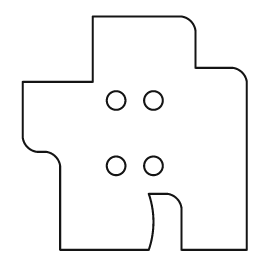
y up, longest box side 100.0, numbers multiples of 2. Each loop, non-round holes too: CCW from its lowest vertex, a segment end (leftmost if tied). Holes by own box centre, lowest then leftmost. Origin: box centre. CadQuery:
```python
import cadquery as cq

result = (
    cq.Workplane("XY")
    .moveTo(-32.0, -50.0)
    .lineTo(6.0, -50.0)
    .threePointArc((8.0, -38.0), (6.0, -26.0))
    .lineTo(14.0, -26.0)
    .threePointArc((18.0, -28.0), (20.0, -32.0))
    .lineTo(20.0, -50.0)
    .lineTo(48.0, -50.0)
    .lineTo(48.0, 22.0)
    .threePointArc((46.0, 26.0), (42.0, 28.0))
    .lineTo(26.0, 28.0)
    .lineTo(26.0, 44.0)
    .threePointArc((24.0, 48.0), (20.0, 50.0))
    .lineTo(-18.0, 50.0)
    .lineTo(-18.0, 22.0)
    .lineTo(-48.0, 22.0)
    .lineTo(-48.0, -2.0)
    .threePointArc((-46.0, -6.0), (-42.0, -8.0))
    .lineTo(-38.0, -8.0)
    .threePointArc((-34.0, -10.0), (-32.0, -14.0))
    .close()
    .moveTo(-8.0, -14.0)
    .circle(4.0)
    .moveTo(8.0, -14.0)
    .circle(4.0)
    .moveTo(-8.0, 14.0)
    .circle(4.0)
    .moveTo(8.0, 14.0)
    .circle(4.0)
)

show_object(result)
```